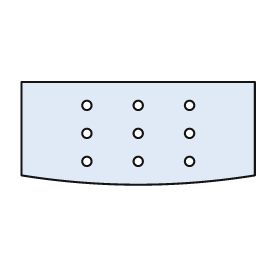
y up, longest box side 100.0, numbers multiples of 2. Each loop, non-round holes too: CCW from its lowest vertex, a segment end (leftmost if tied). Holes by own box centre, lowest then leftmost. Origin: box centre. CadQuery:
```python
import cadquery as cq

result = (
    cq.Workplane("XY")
    .moveTo(-50.0, -18.0)
    .threePointArc((0.0, -22.0), (50.0, -18.0))
    .lineTo(50.0, 22.0)
    .lineTo(-50.0, 22.0)
    .close()
    .moveTo(-22.0, -12.0)
    .circle(2.0)
    .moveTo(0.0, -12.0)
    .circle(2.0)
    .moveTo(22.0, -12.0)
    .circle(2.0)
    .moveTo(-22.0, 0.0)
    .circle(2.0)
    .moveTo(0.0, 0.0)
    .circle(2.0)
    .moveTo(22.0, 0.0)
    .circle(2.0)
    .moveTo(-22.0, 12.0)
    .circle(2.0)
    .moveTo(0.0, 12.0)
    .circle(2.0)
    .moveTo(22.0, 12.0)
    .circle(2.0)
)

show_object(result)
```